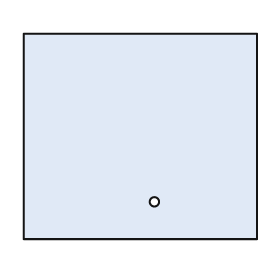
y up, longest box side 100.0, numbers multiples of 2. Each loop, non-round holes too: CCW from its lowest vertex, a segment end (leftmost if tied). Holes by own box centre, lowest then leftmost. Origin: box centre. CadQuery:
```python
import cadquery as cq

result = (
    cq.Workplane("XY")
    .moveTo(-50.0, -44.0)
    .lineTo(50.0, -44.0)
    .lineTo(50.0, 44.0)
    .lineTo(-50.0, 44.0)
    .close()
    .moveTo(6.0, -28.0)
    .circle(2.0)
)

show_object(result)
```